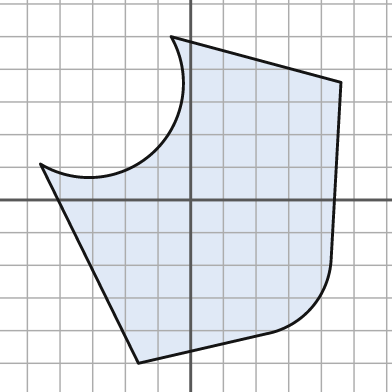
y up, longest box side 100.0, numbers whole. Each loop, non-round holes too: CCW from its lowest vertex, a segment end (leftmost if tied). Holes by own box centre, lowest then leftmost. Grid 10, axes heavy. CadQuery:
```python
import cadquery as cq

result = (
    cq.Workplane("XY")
    .moveTo(-16.0, -50.0)
    .lineTo(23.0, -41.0)
    .threePointArc((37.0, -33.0), (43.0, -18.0))
    .lineTo(46.0, 36.0)
    .lineTo(-6.0, 50.0)
    .threePointArc((-11.0, 15.0), (-46.0, 11.0))
    .close()
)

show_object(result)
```